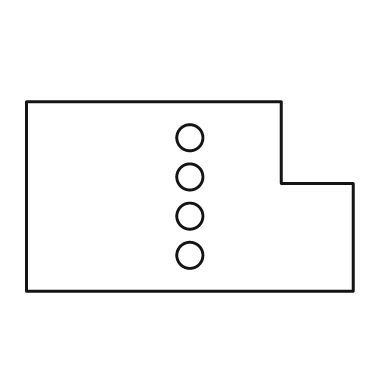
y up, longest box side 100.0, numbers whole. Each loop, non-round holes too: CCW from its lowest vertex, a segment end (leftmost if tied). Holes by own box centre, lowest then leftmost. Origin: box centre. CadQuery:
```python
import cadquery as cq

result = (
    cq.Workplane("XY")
    .moveTo(-50.0, -29.0)
    .lineTo(50.0, -29.0)
    .lineTo(50.0, 4.0)
    .lineTo(28.0, 4.0)
    .lineTo(28.0, 29.0)
    .lineTo(-50.0, 29.0)
    .close()
    .moveTo(0.0, -18.0)
    .circle(4.0)
    .moveTo(0.0, -6.0)
    .circle(4.0)
    .moveTo(0.0, 6.0)
    .circle(4.0)
    .moveTo(0.0, 18.0)
    .circle(4.0)
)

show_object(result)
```